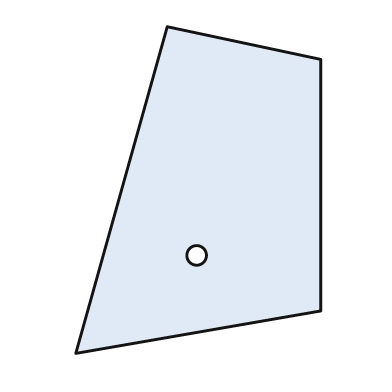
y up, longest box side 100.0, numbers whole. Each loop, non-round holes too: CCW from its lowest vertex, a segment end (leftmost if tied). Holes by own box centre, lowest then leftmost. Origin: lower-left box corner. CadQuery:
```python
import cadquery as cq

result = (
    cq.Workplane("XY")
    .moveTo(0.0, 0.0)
    .lineTo(75.0, 13.0)
    .lineTo(75.0, 90.0)
    .lineTo(28.0, 100.0)
    .close()
    .moveTo(37.0, 30.0)
    .circle(3.0)
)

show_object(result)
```